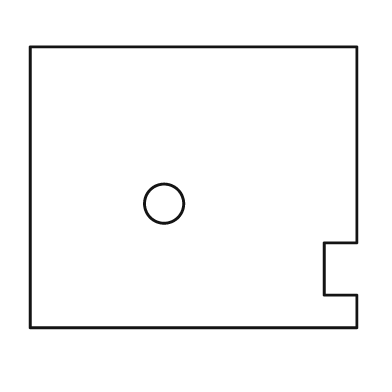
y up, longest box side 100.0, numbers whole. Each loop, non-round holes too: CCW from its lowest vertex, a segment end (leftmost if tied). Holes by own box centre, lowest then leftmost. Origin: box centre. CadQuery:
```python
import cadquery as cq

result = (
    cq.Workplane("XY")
    .moveTo(-50.0, -43.0)
    .lineTo(50.0, -43.0)
    .lineTo(50.0, -33.0)
    .lineTo(40.0, -33.0)
    .lineTo(40.0, -17.0)
    .lineTo(50.0, -17.0)
    .lineTo(50.0, 43.0)
    .lineTo(-50.0, 43.0)
    .close()
    .moveTo(-9.0, -5.0)
    .circle(6.0)
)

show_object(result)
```